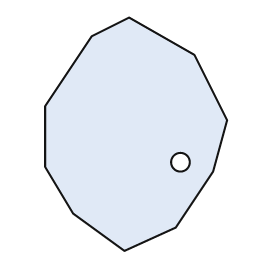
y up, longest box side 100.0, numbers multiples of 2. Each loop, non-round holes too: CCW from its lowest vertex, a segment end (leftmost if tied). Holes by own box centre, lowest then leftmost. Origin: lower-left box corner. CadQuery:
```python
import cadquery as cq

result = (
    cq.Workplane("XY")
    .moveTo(34.0, 0.0)
    .lineTo(56.0, 10.0)
    .lineTo(72.0, 34.0)
    .lineTo(78.0, 56.0)
    .lineTo(64.0, 84.0)
    .lineTo(36.0, 100.0)
    .lineTo(20.0, 92.0)
    .lineTo(0.0, 62.0)
    .lineTo(0.0, 36.0)
    .lineTo(12.0, 16.0)
    .close()
    .moveTo(58.0, 38.0)
    .circle(4.0)
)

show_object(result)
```